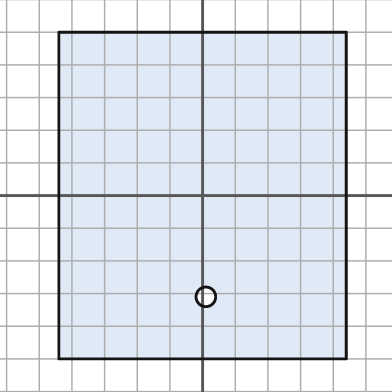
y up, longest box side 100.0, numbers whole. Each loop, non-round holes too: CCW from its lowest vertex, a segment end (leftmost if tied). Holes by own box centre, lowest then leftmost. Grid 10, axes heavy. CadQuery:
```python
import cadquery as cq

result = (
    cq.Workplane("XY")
    .moveTo(-44.0, -50.0)
    .lineTo(44.0, -50.0)
    .lineTo(44.0, 50.0)
    .lineTo(-44.0, 50.0)
    .close()
    .moveTo(1.0, -31.0)
    .circle(3.0)
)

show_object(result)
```